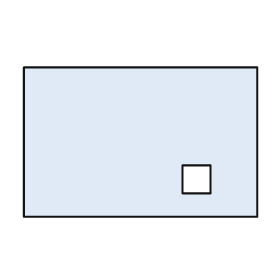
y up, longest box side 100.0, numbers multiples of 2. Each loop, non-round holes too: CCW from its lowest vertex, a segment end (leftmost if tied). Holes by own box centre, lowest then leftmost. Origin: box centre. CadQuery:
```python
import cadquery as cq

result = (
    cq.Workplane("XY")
    .moveTo(-50.0, -32.0)
    .lineTo(50.0, -32.0)
    .lineTo(50.0, 32.0)
    .lineTo(-50.0, 32.0)
    .close()
    .moveTo(18.0, -22.0)
    .lineTo(30.0, -22.0)
    .lineTo(30.0, -10.0)
    .lineTo(18.0, -10.0)
    .close()
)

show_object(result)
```